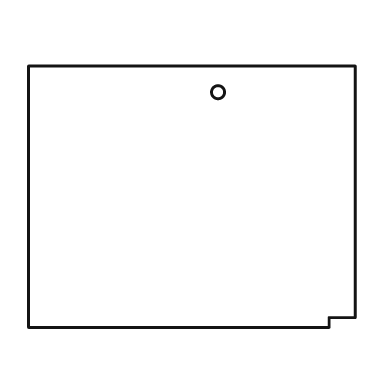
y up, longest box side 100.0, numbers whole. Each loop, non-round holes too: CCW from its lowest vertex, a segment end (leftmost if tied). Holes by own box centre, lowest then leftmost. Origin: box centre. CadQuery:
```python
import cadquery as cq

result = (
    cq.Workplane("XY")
    .moveTo(-50.0, -40.0)
    .lineTo(42.0, -40.0)
    .lineTo(42.0, -37.0)
    .lineTo(50.0, -37.0)
    .lineTo(50.0, 40.0)
    .lineTo(-50.0, 40.0)
    .close()
    .moveTo(8.0, 32.0)
    .circle(2.0)
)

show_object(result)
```